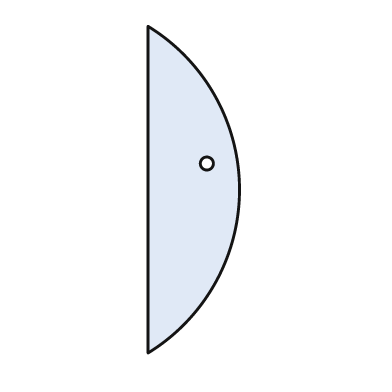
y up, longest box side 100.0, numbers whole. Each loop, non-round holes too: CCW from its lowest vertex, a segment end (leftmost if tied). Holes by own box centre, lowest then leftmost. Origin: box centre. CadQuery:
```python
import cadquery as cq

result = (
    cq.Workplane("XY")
    .moveTo(-14.0, -50.0)
    .threePointArc((14.0, 0.0), (-14.0, 50.0))
    .close()
    .moveTo(4.0, 8.0)
    .circle(2.0)
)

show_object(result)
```